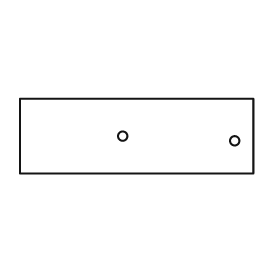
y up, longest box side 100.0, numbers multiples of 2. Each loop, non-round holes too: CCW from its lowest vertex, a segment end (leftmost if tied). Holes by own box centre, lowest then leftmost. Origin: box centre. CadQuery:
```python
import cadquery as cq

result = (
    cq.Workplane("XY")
    .moveTo(-50.0, -16.0)
    .lineTo(50.0, -16.0)
    .lineTo(50.0, 16.0)
    .lineTo(-50.0, 16.0)
    .close()
    .moveTo(42.0, -2.0)
    .circle(2.0)
    .moveTo(-6.0, 0.0)
    .circle(2.0)
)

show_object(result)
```